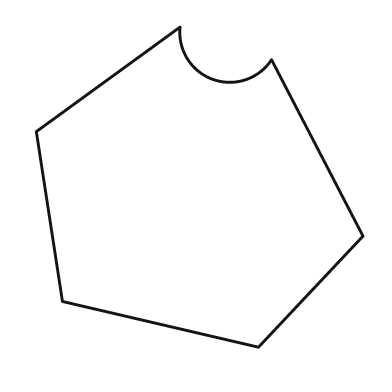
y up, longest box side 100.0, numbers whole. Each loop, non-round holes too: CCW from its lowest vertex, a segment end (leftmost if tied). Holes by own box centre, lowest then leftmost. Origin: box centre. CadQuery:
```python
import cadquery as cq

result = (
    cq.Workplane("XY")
    .moveTo(18.0, -49.0)
    .lineTo(50.0, -15.0)
    .lineTo(22.0, 39.0)
    .threePointArc((4.0, 33.0), (-6.0, 49.0))
    .lineTo(-50.0, 17.0)
    .lineTo(-42.0, -35.0)
    .close()
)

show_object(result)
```